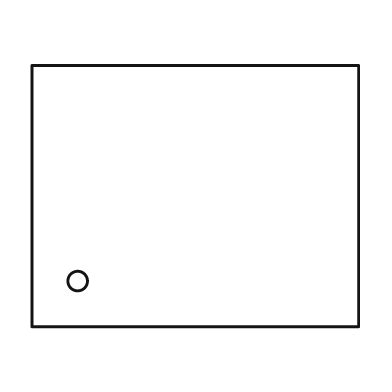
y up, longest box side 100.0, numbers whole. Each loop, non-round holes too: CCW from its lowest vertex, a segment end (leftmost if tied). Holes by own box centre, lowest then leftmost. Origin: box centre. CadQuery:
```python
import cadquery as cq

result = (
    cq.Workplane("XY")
    .moveTo(-50.0, -40.0)
    .lineTo(50.0, -40.0)
    .lineTo(50.0, 40.0)
    .lineTo(-50.0, 40.0)
    .close()
    .moveTo(-36.0, -26.0)
    .circle(3.0)
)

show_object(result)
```